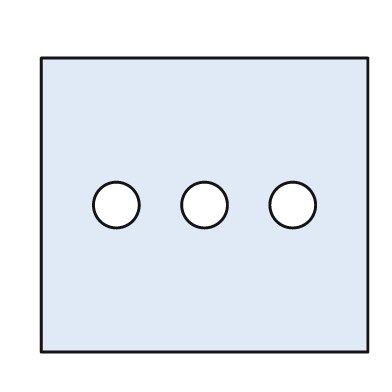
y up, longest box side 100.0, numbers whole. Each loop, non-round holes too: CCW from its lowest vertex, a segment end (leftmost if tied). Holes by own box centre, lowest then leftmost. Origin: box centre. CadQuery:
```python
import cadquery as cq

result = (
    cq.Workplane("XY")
    .moveTo(-50.0, -45.0)
    .lineTo(50.0, -45.0)
    .lineTo(50.0, 45.0)
    .lineTo(-50.0, 45.0)
    .close()
    .moveTo(-27.0, 0.0)
    .circle(7.0)
    .moveTo(0.0, 0.0)
    .circle(7.0)
    .moveTo(27.0, 0.0)
    .circle(7.0)
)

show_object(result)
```